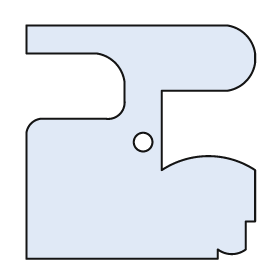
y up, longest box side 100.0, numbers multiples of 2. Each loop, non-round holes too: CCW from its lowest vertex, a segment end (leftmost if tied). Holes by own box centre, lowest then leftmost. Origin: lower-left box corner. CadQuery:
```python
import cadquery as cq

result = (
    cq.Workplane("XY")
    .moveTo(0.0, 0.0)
    .lineTo(82.0, 0.0)
    .lineTo(82.0, 4.0)
    .threePointArc((88.0, 2.0), (94.0, 4.0))
    .lineTo(94.0, 16.0)
    .lineTo(98.0, 16.0)
    .lineTo(98.0, 38.0)
    .threePointArc((78.0, 44.0), (58.0, 38.0))
    .lineTo(58.0, 72.0)
    .lineTo(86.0, 72.0)
    .threePointArc((94.0, 76.0), (98.0, 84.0))
    .lineTo(98.0, 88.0)
    .threePointArc((94.0, 96.0), (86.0, 100.0))
    .lineTo(0.0, 100.0)
    .lineTo(0.0, 88.0)
    .lineTo(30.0, 88.0)
    .threePointArc((38.0, 84.0), (42.0, 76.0))
    .lineTo(42.0, 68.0)
    .threePointArc((40.0, 62.0), (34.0, 60.0))
    .lineTo(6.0, 60.0)
    .threePointArc((2.0, 58.0), (0.0, 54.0))
    .close()
    .moveTo(50.0, 50.0)
    .circle(4.0)
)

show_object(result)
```